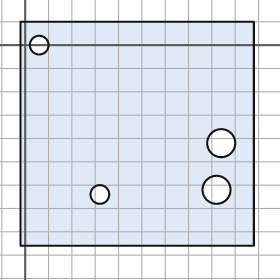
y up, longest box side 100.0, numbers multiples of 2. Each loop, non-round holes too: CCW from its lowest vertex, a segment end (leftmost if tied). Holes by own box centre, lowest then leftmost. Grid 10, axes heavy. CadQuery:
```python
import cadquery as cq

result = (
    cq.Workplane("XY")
    .moveTo(-2.0, -86.0)
    .lineTo(98.0, -86.0)
    .lineTo(98.0, 10.0)
    .lineTo(-2.0, 10.0)
    .close()
    .moveTo(32.0, -64.0)
    .circle(4.0)
    .moveTo(82.0, -62.0)
    .circle(6.0)
    .moveTo(84.0, -42.0)
    .circle(6.0)
    .moveTo(6.0, 0.0)
    .circle(4.0)
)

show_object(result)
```